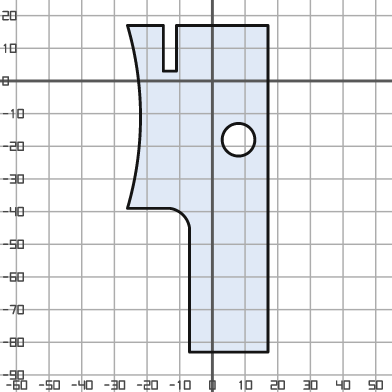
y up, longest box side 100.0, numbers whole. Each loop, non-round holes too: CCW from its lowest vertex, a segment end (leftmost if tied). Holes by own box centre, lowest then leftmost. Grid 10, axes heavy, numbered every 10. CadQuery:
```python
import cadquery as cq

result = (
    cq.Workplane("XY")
    .moveTo(-7.0, -83.0)
    .lineTo(17.0, -83.0)
    .lineTo(17.0, 17.0)
    .lineTo(-11.0, 17.0)
    .lineTo(-11.0, 3.0)
    .lineTo(-15.0, 3.0)
    .lineTo(-15.0, 17.0)
    .lineTo(-26.0, 17.0)
    .threePointArc((-22.0, -11.0), (-26.0, -39.0))
    .lineTo(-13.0, -39.0)
    .threePointArc((-9.0, -41.0), (-7.0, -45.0))
    .close()
    .moveTo(8.0, -18.0)
    .circle(5.0)
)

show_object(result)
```